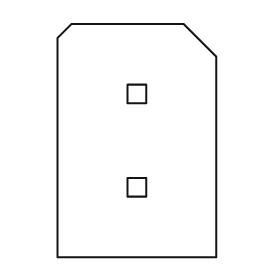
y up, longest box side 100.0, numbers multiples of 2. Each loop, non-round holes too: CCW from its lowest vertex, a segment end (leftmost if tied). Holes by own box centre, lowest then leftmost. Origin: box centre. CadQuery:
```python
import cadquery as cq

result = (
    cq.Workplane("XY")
    .moveTo(-34.0, -50.0)
    .lineTo(34.0, -50.0)
    .lineTo(34.0, 36.0)
    .lineTo(20.0, 50.0)
    .lineTo(-28.0, 50.0)
    .lineTo(-34.0, 44.0)
    .close()
    .moveTo(-4.0, -24.0)
    .lineTo(4.0, -24.0)
    .lineTo(4.0, -16.0)
    .lineTo(-4.0, -16.0)
    .close()
    .moveTo(-4.0, 16.0)
    .lineTo(4.0, 16.0)
    .lineTo(4.0, 24.0)
    .lineTo(-4.0, 24.0)
    .close()
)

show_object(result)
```